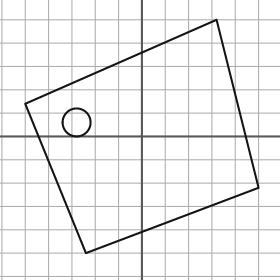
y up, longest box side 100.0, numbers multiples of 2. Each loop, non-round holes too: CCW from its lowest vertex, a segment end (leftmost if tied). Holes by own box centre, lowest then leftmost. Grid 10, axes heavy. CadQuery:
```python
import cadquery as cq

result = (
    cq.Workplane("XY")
    .moveTo(-24.0, -50.0)
    .lineTo(50.0, -22.0)
    .lineTo(32.0, 50.0)
    .lineTo(-50.0, 14.0)
    .close()
    .moveTo(-28.0, 6.0)
    .circle(6.0)
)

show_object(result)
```